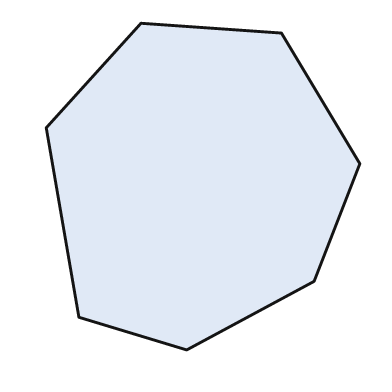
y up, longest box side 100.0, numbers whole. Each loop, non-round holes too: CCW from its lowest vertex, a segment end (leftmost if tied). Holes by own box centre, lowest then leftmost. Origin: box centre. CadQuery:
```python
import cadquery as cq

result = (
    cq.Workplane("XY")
    .moveTo(-5.0, -50.0)
    .lineTo(34.0, -29.0)
    .lineTo(48.0, 7.0)
    .lineTo(24.0, 47.0)
    .lineTo(-19.0, 50.0)
    .lineTo(-48.0, 18.0)
    .lineTo(-38.0, -40.0)
    .close()
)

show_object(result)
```